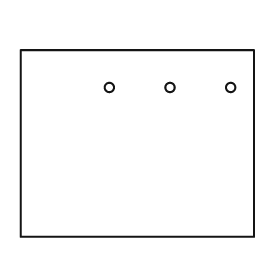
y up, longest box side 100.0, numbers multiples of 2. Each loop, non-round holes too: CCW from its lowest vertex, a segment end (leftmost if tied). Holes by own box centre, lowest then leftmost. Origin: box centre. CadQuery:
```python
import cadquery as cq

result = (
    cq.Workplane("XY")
    .moveTo(-50.0, -40.0)
    .lineTo(50.0, -40.0)
    .lineTo(50.0, 40.0)
    .lineTo(-50.0, 40.0)
    .close()
    .moveTo(-12.0, 24.0)
    .circle(2.0)
    .moveTo(14.0, 24.0)
    .circle(2.0)
    .moveTo(40.0, 24.0)
    .circle(2.0)
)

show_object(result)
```